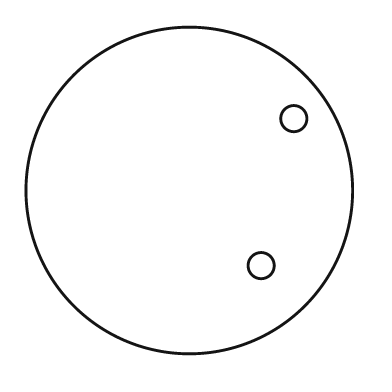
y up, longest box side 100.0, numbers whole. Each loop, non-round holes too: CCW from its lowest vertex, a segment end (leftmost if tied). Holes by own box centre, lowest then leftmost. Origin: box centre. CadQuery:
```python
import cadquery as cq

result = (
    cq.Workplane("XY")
    .moveTo(0.0, 0.0)
    .circle(50.0)
    .moveTo(22.0, -23.0)
    .circle(4.0)
    .moveTo(32.0, 22.0)
    .circle(4.0)
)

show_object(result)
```